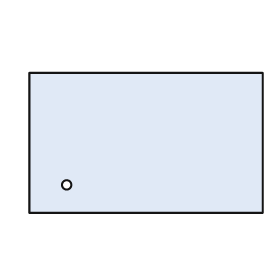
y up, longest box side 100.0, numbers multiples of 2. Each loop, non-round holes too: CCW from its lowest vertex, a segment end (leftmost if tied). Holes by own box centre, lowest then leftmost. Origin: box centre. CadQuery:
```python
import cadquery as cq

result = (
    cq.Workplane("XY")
    .moveTo(-50.0, -30.0)
    .lineTo(50.0, -30.0)
    .lineTo(50.0, 30.0)
    .lineTo(-50.0, 30.0)
    .close()
    .moveTo(-34.0, -18.0)
    .circle(2.0)
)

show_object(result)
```